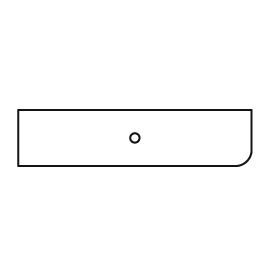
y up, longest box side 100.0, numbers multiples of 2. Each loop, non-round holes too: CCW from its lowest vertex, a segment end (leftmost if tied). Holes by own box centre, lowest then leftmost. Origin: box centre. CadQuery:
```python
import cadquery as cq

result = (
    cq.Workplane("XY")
    .moveTo(-50.0, -12.0)
    .lineTo(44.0, -12.0)
    .threePointArc((48.0, -10.0), (50.0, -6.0))
    .lineTo(50.0, 12.0)
    .lineTo(-50.0, 12.0)
    .close()
    .moveTo(0.0, 0.0)
    .circle(2.0)
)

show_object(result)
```